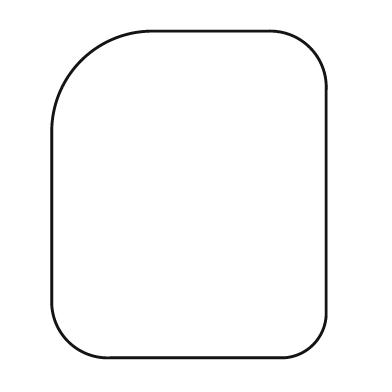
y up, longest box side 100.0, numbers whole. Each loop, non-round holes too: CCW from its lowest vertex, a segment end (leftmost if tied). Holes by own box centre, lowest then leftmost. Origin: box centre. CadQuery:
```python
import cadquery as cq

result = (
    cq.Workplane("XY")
    .moveTo(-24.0, -50.0)
    .lineTo(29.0, -50.0)
    .threePointArc((38.0, -46.0), (42.0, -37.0))
    .lineTo(42.0, 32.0)
    .threePointArc((37.0, 45.0), (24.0, 50.0))
    .lineTo(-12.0, 50.0)
    .threePointArc((-33.0, 41.0), (-42.0, 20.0))
    .lineTo(-42.0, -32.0)
    .threePointArc((-37.0, -45.0), (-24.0, -50.0))
    .close()
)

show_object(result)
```